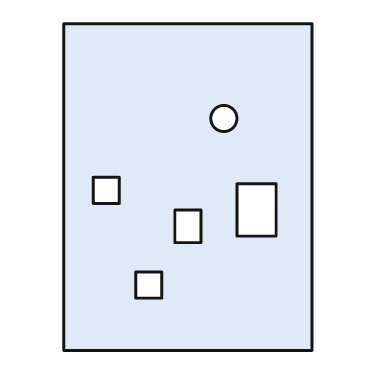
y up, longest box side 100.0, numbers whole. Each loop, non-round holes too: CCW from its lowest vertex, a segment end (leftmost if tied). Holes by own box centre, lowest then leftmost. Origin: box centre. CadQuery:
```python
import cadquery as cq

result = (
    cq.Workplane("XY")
    .moveTo(-38.0, -50.0)
    .lineTo(38.0, -50.0)
    .lineTo(38.0, 50.0)
    .lineTo(-38.0, 50.0)
    .close()
    .moveTo(-16.0, -34.0)
    .lineTo(-8.0, -34.0)
    .lineTo(-8.0, -26.0)
    .lineTo(-16.0, -26.0)
    .close()
    .moveTo(-4.0, -17.0)
    .lineTo(4.0, -17.0)
    .lineTo(4.0, -7.0)
    .lineTo(-4.0, -7.0)
    .close()
    .moveTo(15.0, -15.0)
    .lineTo(27.0, -15.0)
    .lineTo(27.0, 1.0)
    .lineTo(15.0, 1.0)
    .close()
    .moveTo(-29.0, -5.0)
    .lineTo(-21.0, -5.0)
    .lineTo(-21.0, 3.0)
    .lineTo(-29.0, 3.0)
    .close()
    .moveTo(11.0, 21.0)
    .circle(4.0)
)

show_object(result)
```